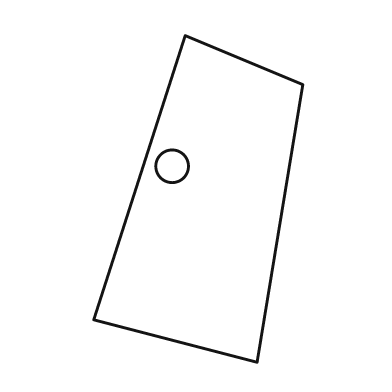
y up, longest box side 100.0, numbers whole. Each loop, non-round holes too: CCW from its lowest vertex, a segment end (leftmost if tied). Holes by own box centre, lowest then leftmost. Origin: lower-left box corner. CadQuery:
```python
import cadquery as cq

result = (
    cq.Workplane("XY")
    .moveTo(50.0, 0.0)
    .lineTo(64.0, 85.0)
    .lineTo(28.0, 100.0)
    .lineTo(0.0, 13.0)
    .close()
    .moveTo(24.0, 60.0)
    .circle(5.0)
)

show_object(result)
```